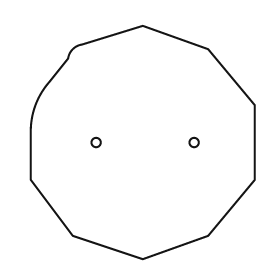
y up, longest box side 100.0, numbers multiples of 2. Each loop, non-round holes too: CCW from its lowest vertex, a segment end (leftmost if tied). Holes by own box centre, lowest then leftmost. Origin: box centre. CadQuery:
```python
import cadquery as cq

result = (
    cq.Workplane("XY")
    .moveTo(0.0, -50.0)
    .lineTo(28.0, -40.0)
    .lineTo(48.0, -16.0)
    .lineTo(48.0, 16.0)
    .lineTo(28.0, 40.0)
    .lineTo(0.0, 50.0)
    .lineTo(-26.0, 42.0)
    .threePointArc((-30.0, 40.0), (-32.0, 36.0))
    .lineTo(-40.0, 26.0)
    .threePointArc((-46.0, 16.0), (-48.0, 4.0))
    .lineTo(-48.0, -16.0)
    .lineTo(-30.0, -40.0)
    .close()
    .moveTo(-20.0, 0.0)
    .circle(2.0)
    .moveTo(22.0, 0.0)
    .circle(2.0)
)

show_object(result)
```